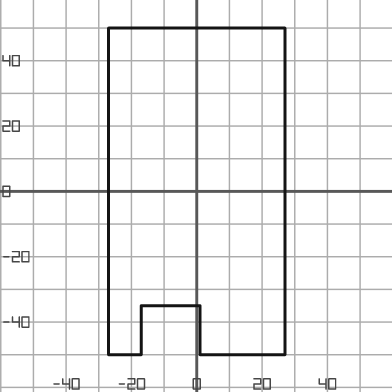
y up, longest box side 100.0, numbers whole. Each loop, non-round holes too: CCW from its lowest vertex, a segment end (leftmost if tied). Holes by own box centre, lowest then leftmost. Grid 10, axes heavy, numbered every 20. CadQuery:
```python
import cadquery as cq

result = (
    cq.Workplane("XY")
    .moveTo(-27.0, -50.0)
    .lineTo(-17.0, -50.0)
    .lineTo(-17.0, -35.0)
    .lineTo(1.0, -35.0)
    .lineTo(1.0, -50.0)
    .lineTo(27.0, -50.0)
    .lineTo(27.0, 50.0)
    .lineTo(-27.0, 50.0)
    .close()
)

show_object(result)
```